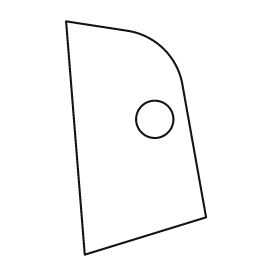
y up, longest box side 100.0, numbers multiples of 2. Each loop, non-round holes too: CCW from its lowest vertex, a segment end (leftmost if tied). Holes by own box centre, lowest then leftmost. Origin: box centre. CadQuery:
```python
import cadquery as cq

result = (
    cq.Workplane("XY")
    .moveTo(-22.0, -50.0)
    .lineTo(30.0, -34.0)
    .lineTo(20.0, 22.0)
    .threePointArc((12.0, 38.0), (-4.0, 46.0))
    .lineTo(-30.0, 50.0)
    .close()
    .moveTo(8.0, 8.0)
    .circle(8.0)
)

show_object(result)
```